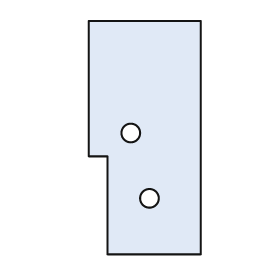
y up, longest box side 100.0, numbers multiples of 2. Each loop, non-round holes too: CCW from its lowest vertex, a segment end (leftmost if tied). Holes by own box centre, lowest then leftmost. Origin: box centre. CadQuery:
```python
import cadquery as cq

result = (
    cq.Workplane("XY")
    .moveTo(-16.0, -50.0)
    .lineTo(24.0, -50.0)
    .lineTo(24.0, 50.0)
    .lineTo(-24.0, 50.0)
    .lineTo(-24.0, -8.0)
    .lineTo(-16.0, -8.0)
    .close()
    .moveTo(2.0, -26.0)
    .circle(4.0)
    .moveTo(-6.0, 2.0)
    .circle(4.0)
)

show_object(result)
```